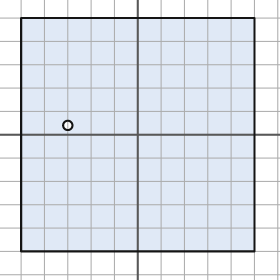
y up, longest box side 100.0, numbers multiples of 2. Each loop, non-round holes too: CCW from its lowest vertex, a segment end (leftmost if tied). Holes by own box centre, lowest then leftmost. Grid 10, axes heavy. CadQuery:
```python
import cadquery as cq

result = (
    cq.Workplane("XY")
    .moveTo(-50.0, -50.0)
    .lineTo(50.0, -50.0)
    .lineTo(50.0, 50.0)
    .lineTo(-50.0, 50.0)
    .close()
    .moveTo(-30.0, 4.0)
    .circle(2.0)
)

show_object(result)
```